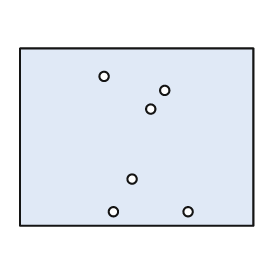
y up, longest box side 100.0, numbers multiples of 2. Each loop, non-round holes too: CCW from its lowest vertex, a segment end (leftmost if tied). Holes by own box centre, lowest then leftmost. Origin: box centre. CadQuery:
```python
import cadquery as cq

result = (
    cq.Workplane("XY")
    .moveTo(-50.0, -38.0)
    .lineTo(50.0, -38.0)
    .lineTo(50.0, 38.0)
    .lineTo(-50.0, 38.0)
    .close()
    .moveTo(-10.0, -32.0)
    .circle(2.0)
    .moveTo(22.0, -32.0)
    .circle(2.0)
    .moveTo(-2.0, -18.0)
    .circle(2.0)
    .moveTo(6.0, 12.0)
    .circle(2.0)
    .moveTo(12.0, 20.0)
    .circle(2.0)
    .moveTo(-14.0, 26.0)
    .circle(2.0)
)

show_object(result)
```